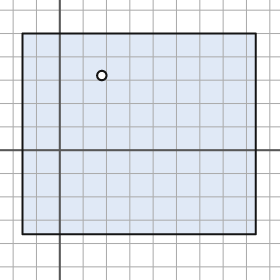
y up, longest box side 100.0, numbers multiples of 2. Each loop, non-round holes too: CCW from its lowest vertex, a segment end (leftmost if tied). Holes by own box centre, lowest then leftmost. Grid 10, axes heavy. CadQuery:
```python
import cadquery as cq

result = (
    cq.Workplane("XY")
    .moveTo(-16.0, -36.0)
    .lineTo(84.0, -36.0)
    .lineTo(84.0, 50.0)
    .lineTo(-16.0, 50.0)
    .close()
    .moveTo(18.0, 32.0)
    .circle(2.0)
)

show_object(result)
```